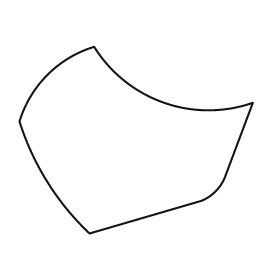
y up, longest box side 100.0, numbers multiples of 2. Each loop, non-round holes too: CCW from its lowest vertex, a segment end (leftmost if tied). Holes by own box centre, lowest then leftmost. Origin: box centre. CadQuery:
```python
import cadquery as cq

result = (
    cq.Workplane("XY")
    .moveTo(-20.0, -40.0)
    .lineTo(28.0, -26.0)
    .threePointArc((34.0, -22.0), (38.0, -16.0))
    .lineTo(50.0, 16.0)
    .threePointArc((12.0, 16.0), (-18.0, 40.0))
    .threePointArc((-38.0, 28.0), (-50.0, 8.0))
    .threePointArc((-38.0, -18.0), (-20.0, -40.0))
    .close()
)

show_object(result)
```